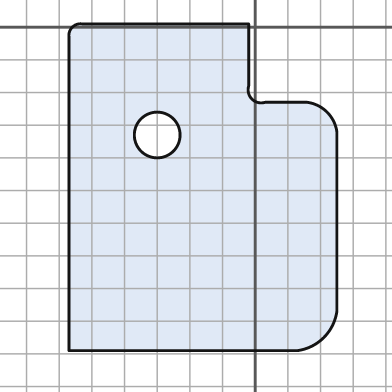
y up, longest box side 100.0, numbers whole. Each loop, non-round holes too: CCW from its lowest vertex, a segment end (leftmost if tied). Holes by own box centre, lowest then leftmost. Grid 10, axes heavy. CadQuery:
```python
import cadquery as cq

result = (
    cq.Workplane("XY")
    .moveTo(-57.0, -99.0)
    .lineTo(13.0, -99.0)
    .threePointArc((21.0, -95.0), (25.0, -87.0))
    .lineTo(25.0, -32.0)
    .threePointArc((22.0, -26.0), (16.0, -23.0))
    .lineTo(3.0, -23.0)
    .threePointArc((-1.0, -22.0), (-2.0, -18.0))
    .lineTo(-2.0, 1.0)
    .lineTo(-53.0, 1.0)
    .threePointArc((-56.0, 0.0), (-57.0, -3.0))
    .close()
    .moveTo(-30.0, -33.0)
    .circle(7.0)
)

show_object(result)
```